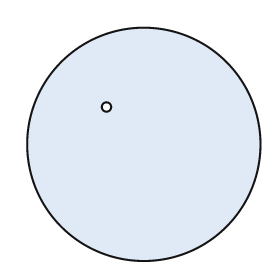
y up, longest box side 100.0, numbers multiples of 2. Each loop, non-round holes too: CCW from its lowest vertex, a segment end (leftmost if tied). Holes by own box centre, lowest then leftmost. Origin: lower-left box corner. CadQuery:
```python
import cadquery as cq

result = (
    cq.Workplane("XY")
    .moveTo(50.0, 50.0)
    .circle(50.0)
    .moveTo(34.0, 66.0)
    .circle(2.0)
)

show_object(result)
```